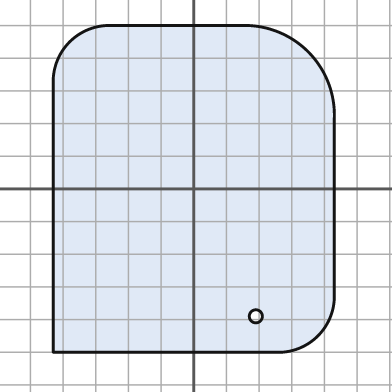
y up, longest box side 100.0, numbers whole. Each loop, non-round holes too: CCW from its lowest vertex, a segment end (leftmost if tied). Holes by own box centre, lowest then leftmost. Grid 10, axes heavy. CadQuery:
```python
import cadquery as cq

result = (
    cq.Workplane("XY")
    .moveTo(-43.0, -50.0)
    .lineTo(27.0, -50.0)
    .threePointArc((38.0, -45.0), (43.0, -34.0))
    .lineTo(43.0, 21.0)
    .threePointArc((35.0, 42.0), (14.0, 50.0))
    .lineTo(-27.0, 50.0)
    .threePointArc((-38.0, 45.0), (-43.0, 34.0))
    .close()
    .moveTo(19.0, -39.0)
    .circle(2.0)
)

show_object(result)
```